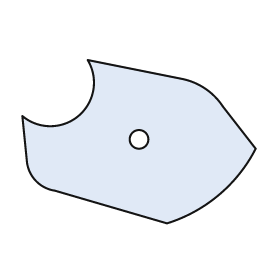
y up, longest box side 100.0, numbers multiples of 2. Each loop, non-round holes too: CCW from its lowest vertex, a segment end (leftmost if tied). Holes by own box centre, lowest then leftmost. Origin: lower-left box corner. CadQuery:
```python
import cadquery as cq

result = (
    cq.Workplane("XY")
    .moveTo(62.0, 0.0)
    .threePointArc((84.0, 12.0), (100.0, 32.0))
    .lineTo(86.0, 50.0)
    .threePointArc((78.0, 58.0), (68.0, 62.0))
    .lineTo(28.0, 70.0)
    .threePointArc((24.0, 46.0), (0.0, 46.0))
    .lineTo(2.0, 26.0)
    .threePointArc((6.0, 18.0), (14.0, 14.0))
    .close()
    .moveTo(50.0, 36.0)
    .circle(4.0)
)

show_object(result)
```